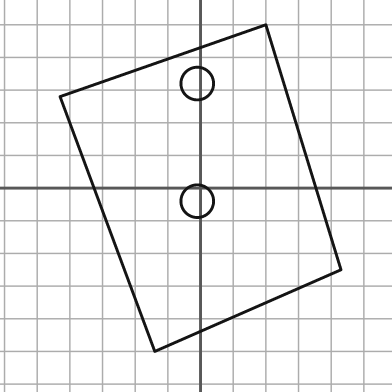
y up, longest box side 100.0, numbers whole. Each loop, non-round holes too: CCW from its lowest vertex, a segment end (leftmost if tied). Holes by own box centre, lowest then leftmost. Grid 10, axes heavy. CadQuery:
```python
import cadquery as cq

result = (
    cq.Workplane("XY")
    .moveTo(-14.0, -50.0)
    .lineTo(43.0, -25.0)
    .lineTo(20.0, 50.0)
    .lineTo(-43.0, 28.0)
    .close()
    .moveTo(-1.0, -4.0)
    .circle(5.0)
    .moveTo(-1.0, 32.0)
    .circle(5.0)
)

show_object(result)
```